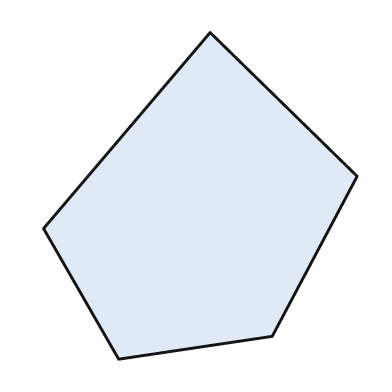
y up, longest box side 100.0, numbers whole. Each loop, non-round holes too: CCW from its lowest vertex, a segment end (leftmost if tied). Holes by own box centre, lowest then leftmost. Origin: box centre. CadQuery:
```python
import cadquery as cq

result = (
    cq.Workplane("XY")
    .moveTo(-25.0, -50.0)
    .lineTo(22.0, -43.0)
    .lineTo(48.0, 6.0)
    .lineTo(3.0, 50.0)
    .lineTo(-48.0, -10.0)
    .close()
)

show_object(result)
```